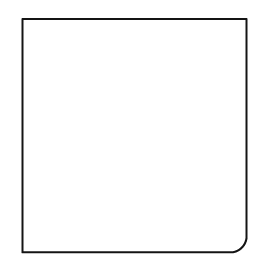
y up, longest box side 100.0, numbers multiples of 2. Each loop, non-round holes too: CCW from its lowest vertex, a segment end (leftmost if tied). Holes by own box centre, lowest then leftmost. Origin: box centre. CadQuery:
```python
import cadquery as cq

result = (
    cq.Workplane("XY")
    .moveTo(-48.0, -50.0)
    .lineTo(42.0, -50.0)
    .threePointArc((46.0, -48.0), (48.0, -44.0))
    .lineTo(48.0, 50.0)
    .lineTo(-48.0, 50.0)
    .close()
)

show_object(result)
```